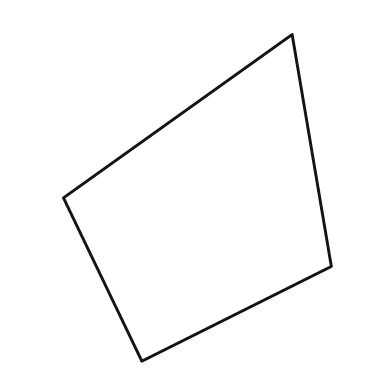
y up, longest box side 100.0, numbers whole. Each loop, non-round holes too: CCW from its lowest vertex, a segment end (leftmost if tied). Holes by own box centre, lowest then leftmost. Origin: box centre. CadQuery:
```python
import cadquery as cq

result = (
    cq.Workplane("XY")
    .moveTo(-17.0, -50.0)
    .lineTo(41.0, -21.0)
    .lineTo(29.0, 50.0)
    .lineTo(-41.0, 0.0)
    .close()
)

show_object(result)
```